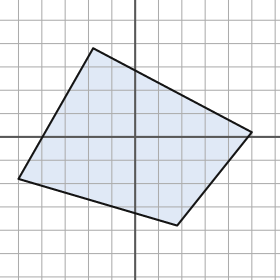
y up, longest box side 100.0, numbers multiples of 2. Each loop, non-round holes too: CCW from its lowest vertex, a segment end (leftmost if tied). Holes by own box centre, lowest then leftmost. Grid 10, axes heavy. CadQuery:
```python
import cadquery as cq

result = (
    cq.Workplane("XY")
    .moveTo(18.0, -38.0)
    .lineTo(50.0, 2.0)
    .lineTo(-18.0, 38.0)
    .lineTo(-50.0, -18.0)
    .close()
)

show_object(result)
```